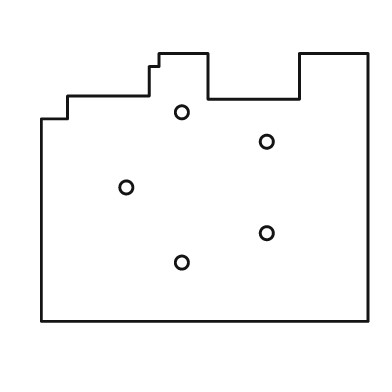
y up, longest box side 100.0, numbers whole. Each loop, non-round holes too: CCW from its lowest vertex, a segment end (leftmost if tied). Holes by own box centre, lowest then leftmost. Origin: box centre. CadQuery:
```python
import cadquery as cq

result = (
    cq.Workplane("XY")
    .moveTo(-50.0, -41.0)
    .lineTo(50.0, -41.0)
    .lineTo(50.0, 41.0)
    .lineTo(29.0, 41.0)
    .lineTo(29.0, 27.0)
    .lineTo(1.0, 27.0)
    .lineTo(1.0, 41.0)
    .lineTo(-14.0, 41.0)
    .lineTo(-14.0, 37.0)
    .lineTo(-17.0, 37.0)
    .lineTo(-17.0, 28.0)
    .lineTo(-42.0, 28.0)
    .lineTo(-42.0, 21.0)
    .lineTo(-50.0, 21.0)
    .close()
    .moveTo(-7.0, -23.0)
    .circle(2.0)
    .moveTo(19.0, -14.0)
    .circle(2.0)
    .moveTo(-24.0, 0.0)
    .circle(2.0)
    .moveTo(19.0, 14.0)
    .circle(2.0)
    .moveTo(-7.0, 23.0)
    .circle(2.0)
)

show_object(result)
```